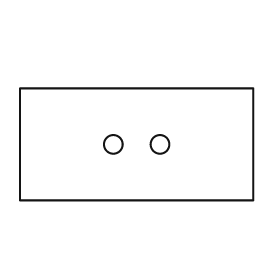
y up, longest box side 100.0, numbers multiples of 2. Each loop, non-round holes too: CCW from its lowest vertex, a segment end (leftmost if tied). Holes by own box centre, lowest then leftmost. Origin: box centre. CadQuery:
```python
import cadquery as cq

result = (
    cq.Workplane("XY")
    .moveTo(-50.0, -24.0)
    .lineTo(50.0, -24.0)
    .lineTo(50.0, 24.0)
    .lineTo(-50.0, 24.0)
    .close()
    .moveTo(-10.0, 0.0)
    .circle(4.0)
    .moveTo(10.0, 0.0)
    .circle(4.0)
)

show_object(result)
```